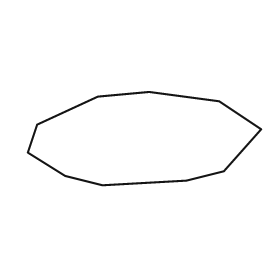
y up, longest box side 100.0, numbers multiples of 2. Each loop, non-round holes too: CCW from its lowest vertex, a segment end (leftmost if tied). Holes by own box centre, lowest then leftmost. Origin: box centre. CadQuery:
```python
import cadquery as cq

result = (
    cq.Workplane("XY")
    .moveTo(-18.0, -20.0)
    .lineTo(18.0, -18.0)
    .lineTo(34.0, -14.0)
    .lineTo(50.0, 4.0)
    .lineTo(32.0, 16.0)
    .lineTo(2.0, 20.0)
    .lineTo(-20.0, 18.0)
    .lineTo(-46.0, 6.0)
    .lineTo(-50.0, -6.0)
    .lineTo(-34.0, -16.0)
    .close()
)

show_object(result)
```